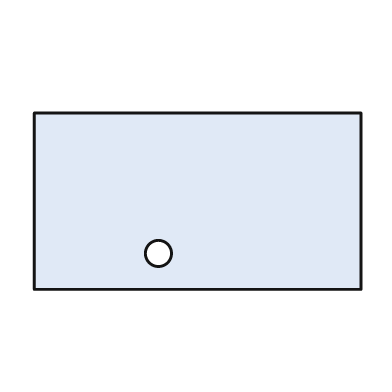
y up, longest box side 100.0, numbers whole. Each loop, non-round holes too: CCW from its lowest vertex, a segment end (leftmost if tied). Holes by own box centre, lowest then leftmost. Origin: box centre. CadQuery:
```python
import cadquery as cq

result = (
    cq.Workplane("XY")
    .moveTo(-50.0, -27.0)
    .lineTo(50.0, -27.0)
    .lineTo(50.0, 27.0)
    .lineTo(-50.0, 27.0)
    .close()
    .moveTo(-12.0, -16.0)
    .circle(4.0)
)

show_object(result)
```